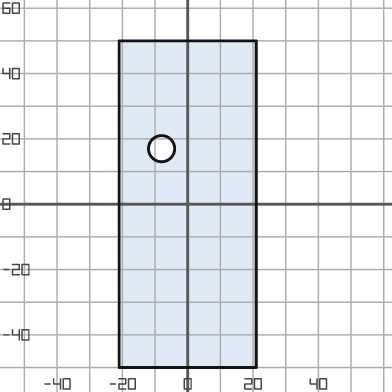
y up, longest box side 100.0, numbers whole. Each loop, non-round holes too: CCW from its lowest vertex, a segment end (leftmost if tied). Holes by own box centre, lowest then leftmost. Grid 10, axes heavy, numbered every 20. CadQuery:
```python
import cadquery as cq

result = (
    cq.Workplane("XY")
    .moveTo(-21.0, -50.0)
    .lineTo(21.0, -50.0)
    .lineTo(21.0, 50.0)
    .lineTo(-21.0, 50.0)
    .close()
    .moveTo(-8.0, 17.0)
    .circle(4.0)
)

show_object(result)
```